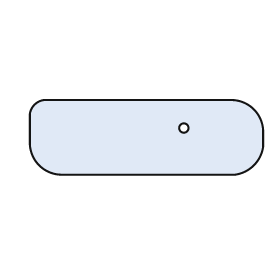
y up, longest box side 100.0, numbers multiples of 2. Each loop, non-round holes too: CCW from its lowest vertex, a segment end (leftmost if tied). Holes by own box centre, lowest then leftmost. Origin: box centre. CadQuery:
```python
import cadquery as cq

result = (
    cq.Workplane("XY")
    .moveTo(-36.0, -16.0)
    .lineTo(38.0, -16.0)
    .threePointArc((46.0, -12.0), (50.0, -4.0))
    .lineTo(50.0, 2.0)
    .threePointArc((46.0, 12.0), (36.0, 16.0))
    .lineTo(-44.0, 16.0)
    .threePointArc((-48.0, 14.0), (-50.0, 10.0))
    .lineTo(-50.0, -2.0)
    .threePointArc((-46.0, -12.0), (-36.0, -16.0))
    .close()
    .moveTo(16.0, 4.0)
    .circle(2.0)
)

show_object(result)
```